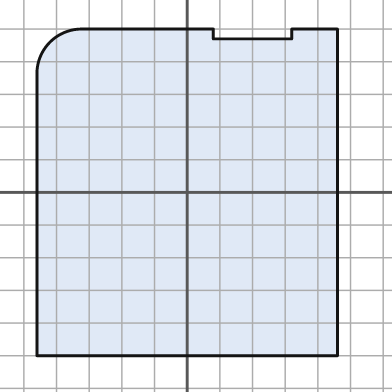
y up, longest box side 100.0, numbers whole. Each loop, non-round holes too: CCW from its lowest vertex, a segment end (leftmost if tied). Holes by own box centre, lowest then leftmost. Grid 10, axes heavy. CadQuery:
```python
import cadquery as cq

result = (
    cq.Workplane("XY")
    .moveTo(-46.0, -50.0)
    .lineTo(46.0, -50.0)
    .lineTo(46.0, 50.0)
    .lineTo(32.0, 50.0)
    .lineTo(32.0, 47.0)
    .lineTo(8.0, 47.0)
    .lineTo(8.0, 50.0)
    .lineTo(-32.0, 50.0)
    .threePointArc((-42.0, 46.0), (-46.0, 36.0))
    .close()
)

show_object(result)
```